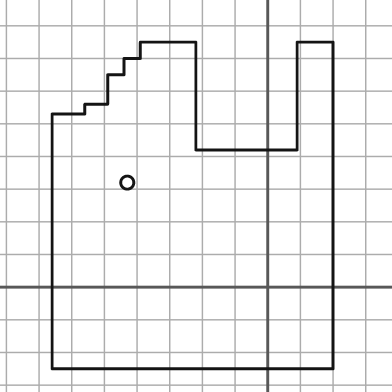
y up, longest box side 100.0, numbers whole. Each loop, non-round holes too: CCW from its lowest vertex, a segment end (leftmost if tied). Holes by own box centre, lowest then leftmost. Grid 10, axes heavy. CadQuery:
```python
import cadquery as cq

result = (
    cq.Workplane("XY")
    .moveTo(-66.0, -25.0)
    .lineTo(20.0, -25.0)
    .lineTo(20.0, 75.0)
    .lineTo(9.0, 75.0)
    .lineTo(9.0, 42.0)
    .lineTo(-22.0, 42.0)
    .lineTo(-22.0, 75.0)
    .lineTo(-39.0, 75.0)
    .lineTo(-39.0, 70.0)
    .lineTo(-44.0, 70.0)
    .lineTo(-44.0, 65.0)
    .lineTo(-49.0, 65.0)
    .lineTo(-49.0, 56.0)
    .lineTo(-56.0, 56.0)
    .lineTo(-56.0, 53.0)
    .lineTo(-66.0, 53.0)
    .close()
    .moveTo(-43.0, 32.0)
    .circle(2.0)
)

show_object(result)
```